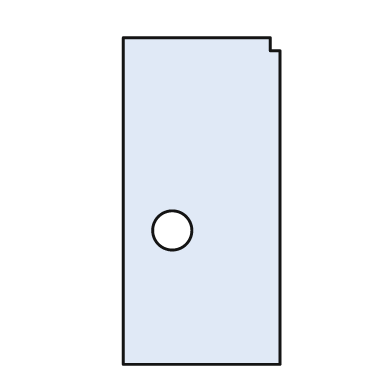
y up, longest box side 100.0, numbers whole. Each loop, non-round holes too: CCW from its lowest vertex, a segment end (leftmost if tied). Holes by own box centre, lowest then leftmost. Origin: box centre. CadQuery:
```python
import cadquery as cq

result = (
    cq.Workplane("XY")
    .moveTo(-24.0, -50.0)
    .lineTo(24.0, -50.0)
    .lineTo(24.0, 46.0)
    .lineTo(21.0, 46.0)
    .lineTo(21.0, 50.0)
    .lineTo(-24.0, 50.0)
    .close()
    .moveTo(-9.0, -9.0)
    .circle(6.0)
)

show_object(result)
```